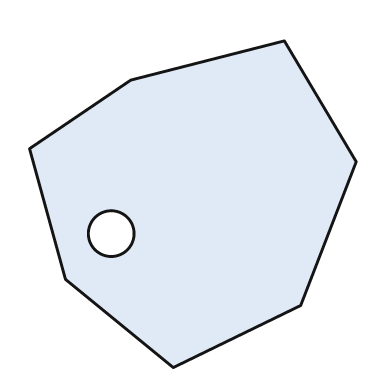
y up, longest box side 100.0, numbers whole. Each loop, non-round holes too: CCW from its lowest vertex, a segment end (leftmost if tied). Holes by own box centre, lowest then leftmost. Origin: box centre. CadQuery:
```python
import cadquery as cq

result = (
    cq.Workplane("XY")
    .moveTo(-6.0, -50.0)
    .lineTo(33.0, -31.0)
    .lineTo(50.0, 13.0)
    .lineTo(28.0, 50.0)
    .lineTo(-19.0, 38.0)
    .lineTo(-50.0, 17.0)
    .lineTo(-39.0, -23.0)
    .close()
    .moveTo(-25.0, -9.0)
    .circle(7.0)
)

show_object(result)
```